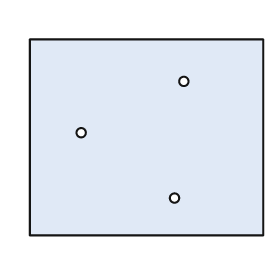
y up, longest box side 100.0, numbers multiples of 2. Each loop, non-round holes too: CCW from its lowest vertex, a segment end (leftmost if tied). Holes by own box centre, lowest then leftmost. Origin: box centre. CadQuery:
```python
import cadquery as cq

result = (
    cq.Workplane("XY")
    .moveTo(-50.0, -42.0)
    .lineTo(50.0, -42.0)
    .lineTo(50.0, 42.0)
    .lineTo(-50.0, 42.0)
    .close()
    .moveTo(12.0, -26.0)
    .circle(2.0)
    .moveTo(-28.0, 2.0)
    .circle(2.0)
    .moveTo(16.0, 24.0)
    .circle(2.0)
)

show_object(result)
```